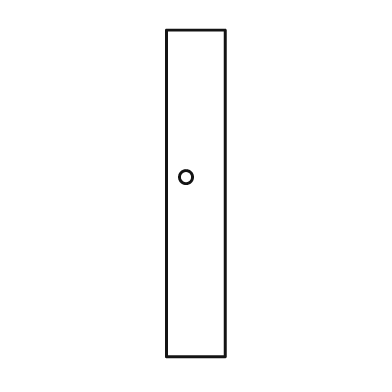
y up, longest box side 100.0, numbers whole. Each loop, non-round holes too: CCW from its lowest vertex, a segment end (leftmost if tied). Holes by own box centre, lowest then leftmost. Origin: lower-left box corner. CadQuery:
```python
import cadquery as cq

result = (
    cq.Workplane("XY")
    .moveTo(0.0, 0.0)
    .lineTo(18.0, 0.0)
    .lineTo(18.0, 100.0)
    .lineTo(0.0, 100.0)
    .close()
    .moveTo(6.0, 55.0)
    .circle(2.0)
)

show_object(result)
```